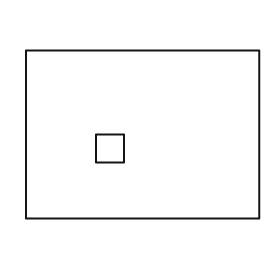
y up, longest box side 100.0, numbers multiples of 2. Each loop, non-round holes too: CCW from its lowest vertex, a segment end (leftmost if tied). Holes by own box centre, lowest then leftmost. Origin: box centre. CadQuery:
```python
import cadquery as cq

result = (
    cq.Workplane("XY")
    .moveTo(-50.0, -36.0)
    .lineTo(50.0, -36.0)
    .lineTo(50.0, 36.0)
    .lineTo(-50.0, 36.0)
    .close()
    .moveTo(-20.0, -12.0)
    .lineTo(-8.0, -12.0)
    .lineTo(-8.0, 0.0)
    .lineTo(-20.0, 0.0)
    .close()
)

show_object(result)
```